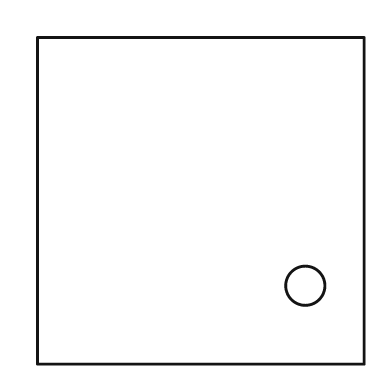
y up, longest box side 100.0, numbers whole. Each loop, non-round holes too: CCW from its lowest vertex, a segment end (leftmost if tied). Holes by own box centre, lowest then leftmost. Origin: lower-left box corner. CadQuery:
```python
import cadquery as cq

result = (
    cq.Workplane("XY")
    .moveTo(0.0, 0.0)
    .lineTo(100.0, 0.0)
    .lineTo(100.0, 100.0)
    .lineTo(0.0, 100.0)
    .close()
    .moveTo(82.0, 24.0)
    .circle(6.0)
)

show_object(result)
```